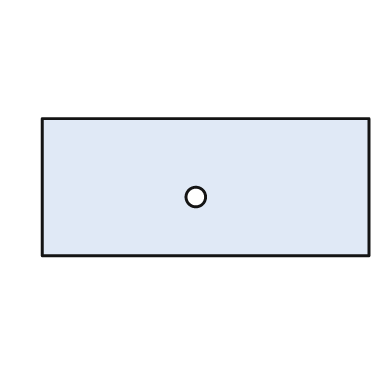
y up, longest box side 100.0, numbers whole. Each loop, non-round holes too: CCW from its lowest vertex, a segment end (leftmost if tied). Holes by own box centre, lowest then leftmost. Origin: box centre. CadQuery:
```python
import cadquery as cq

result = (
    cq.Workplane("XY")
    .moveTo(-50.0, -21.0)
    .lineTo(50.0, -21.0)
    .lineTo(50.0, 21.0)
    .lineTo(-50.0, 21.0)
    .close()
    .moveTo(-3.0, -3.0)
    .circle(3.0)
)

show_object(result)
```